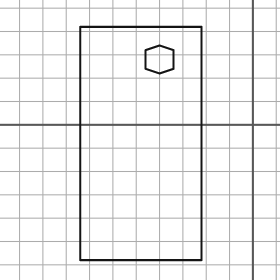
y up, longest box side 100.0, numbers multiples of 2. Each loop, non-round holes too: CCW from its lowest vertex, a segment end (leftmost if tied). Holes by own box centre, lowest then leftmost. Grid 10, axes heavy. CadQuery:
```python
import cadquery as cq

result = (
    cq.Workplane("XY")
    .moveTo(-74.0, -58.0)
    .lineTo(-22.0, -58.0)
    .lineTo(-22.0, 42.0)
    .lineTo(-74.0, 42.0)
    .close()
    .moveTo(-40.0, 22.0)
    .lineTo(-34.0, 24.0)
    .lineTo(-34.0, 32.0)
    .lineTo(-40.0, 34.0)
    .lineTo(-46.0, 32.0)
    .lineTo(-46.0, 24.0)
    .close()
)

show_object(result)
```